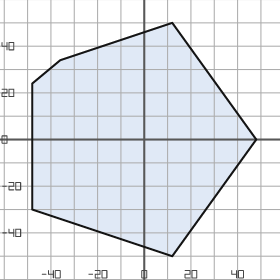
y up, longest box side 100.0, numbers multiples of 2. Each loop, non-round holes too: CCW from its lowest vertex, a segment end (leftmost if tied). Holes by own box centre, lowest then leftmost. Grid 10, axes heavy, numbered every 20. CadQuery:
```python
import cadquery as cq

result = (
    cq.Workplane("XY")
    .moveTo(12.0, -50.0)
    .lineTo(48.0, 0.0)
    .lineTo(12.0, 50.0)
    .lineTo(-36.0, 34.0)
    .lineTo(-48.0, 24.0)
    .lineTo(-48.0, -30.0)
    .close()
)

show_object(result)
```